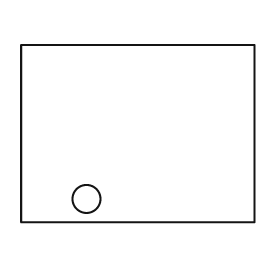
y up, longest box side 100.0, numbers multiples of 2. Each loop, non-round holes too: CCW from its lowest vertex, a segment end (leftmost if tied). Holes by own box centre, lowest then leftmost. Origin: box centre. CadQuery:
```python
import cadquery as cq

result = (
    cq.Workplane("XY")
    .moveTo(-50.0, -38.0)
    .lineTo(50.0, -38.0)
    .lineTo(50.0, 38.0)
    .lineTo(-50.0, 38.0)
    .close()
    .moveTo(-22.0, -28.0)
    .circle(6.0)
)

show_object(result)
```